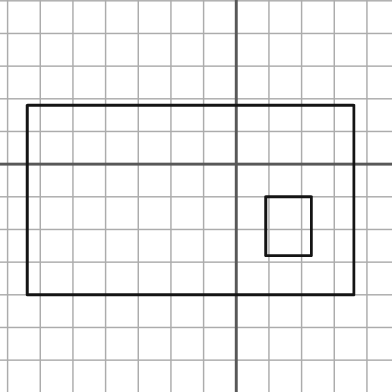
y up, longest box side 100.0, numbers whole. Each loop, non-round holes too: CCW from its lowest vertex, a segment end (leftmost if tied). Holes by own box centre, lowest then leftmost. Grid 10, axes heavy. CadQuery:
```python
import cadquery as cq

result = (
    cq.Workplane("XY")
    .moveTo(-64.0, -40.0)
    .lineTo(36.0, -40.0)
    .lineTo(36.0, 18.0)
    .lineTo(-64.0, 18.0)
    .close()
    .moveTo(9.0, -28.0)
    .lineTo(23.0, -28.0)
    .lineTo(23.0, -10.0)
    .lineTo(9.0, -10.0)
    .close()
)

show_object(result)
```